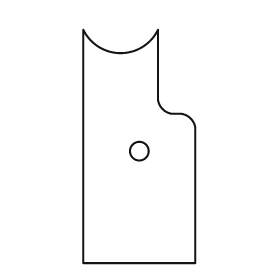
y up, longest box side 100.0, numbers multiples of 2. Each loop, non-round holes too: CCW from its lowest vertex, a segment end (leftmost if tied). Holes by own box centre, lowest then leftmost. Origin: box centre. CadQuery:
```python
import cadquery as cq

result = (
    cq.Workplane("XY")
    .moveTo(-24.0, -50.0)
    .lineTo(24.0, -50.0)
    .lineTo(24.0, 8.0)
    .threePointArc((22.0, 12.0), (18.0, 14.0))
    .lineTo(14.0, 14.0)
    .threePointArc((10.0, 16.0), (8.0, 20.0))
    .lineTo(8.0, 50.0)
    .threePointArc((-8.0, 40.0), (-24.0, 50.0))
    .close()
    .moveTo(0.0, -2.0)
    .circle(4.0)
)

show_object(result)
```